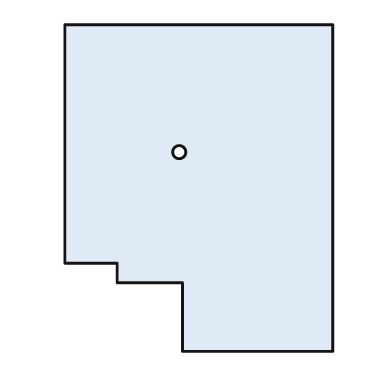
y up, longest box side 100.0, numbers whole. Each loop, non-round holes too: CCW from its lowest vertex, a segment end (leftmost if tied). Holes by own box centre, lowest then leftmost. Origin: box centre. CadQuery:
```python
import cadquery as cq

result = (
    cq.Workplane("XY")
    .moveTo(-5.0, -50.0)
    .lineTo(41.0, -50.0)
    .lineTo(41.0, 50.0)
    .lineTo(-41.0, 50.0)
    .lineTo(-41.0, -23.0)
    .lineTo(-25.0, -23.0)
    .lineTo(-25.0, -29.0)
    .lineTo(-5.0, -29.0)
    .close()
    .moveTo(-6.0, 11.0)
    .circle(2.0)
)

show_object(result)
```